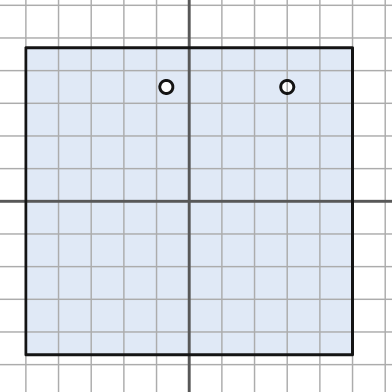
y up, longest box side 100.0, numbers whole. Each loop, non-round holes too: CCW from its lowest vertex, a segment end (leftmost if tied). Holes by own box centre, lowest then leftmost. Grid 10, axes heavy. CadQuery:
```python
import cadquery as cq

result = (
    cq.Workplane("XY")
    .moveTo(-50.0, -47.0)
    .lineTo(50.0, -47.0)
    .lineTo(50.0, 47.0)
    .lineTo(-50.0, 47.0)
    .close()
    .moveTo(-7.0, 35.0)
    .circle(2.0)
    .moveTo(30.0, 35.0)
    .circle(2.0)
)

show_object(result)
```